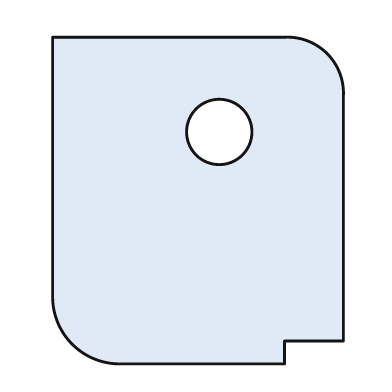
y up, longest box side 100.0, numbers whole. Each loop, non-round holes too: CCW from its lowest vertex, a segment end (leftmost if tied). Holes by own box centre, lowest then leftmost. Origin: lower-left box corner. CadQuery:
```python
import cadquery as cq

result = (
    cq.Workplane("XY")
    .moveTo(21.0, 0.0)
    .lineTo(71.0, 0.0)
    .lineTo(71.0, 7.0)
    .lineTo(89.0, 7.0)
    .lineTo(89.0, 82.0)
    .threePointArc((84.0, 95.0), (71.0, 100.0))
    .lineTo(0.0, 100.0)
    .lineTo(0.0, 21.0)
    .threePointArc((6.0, 6.0), (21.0, 0.0))
    .close()
    .moveTo(51.0, 71.0)
    .circle(10.0)
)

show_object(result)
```